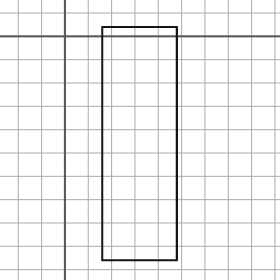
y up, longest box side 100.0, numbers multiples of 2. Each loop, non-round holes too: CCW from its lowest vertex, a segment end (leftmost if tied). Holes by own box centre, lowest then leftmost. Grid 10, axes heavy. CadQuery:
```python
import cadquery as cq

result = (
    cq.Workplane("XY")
    .moveTo(16.0, -96.0)
    .lineTo(48.0, -96.0)
    .lineTo(48.0, 4.0)
    .lineTo(16.0, 4.0)
    .close()
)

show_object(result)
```